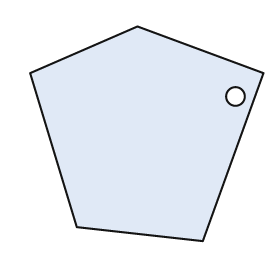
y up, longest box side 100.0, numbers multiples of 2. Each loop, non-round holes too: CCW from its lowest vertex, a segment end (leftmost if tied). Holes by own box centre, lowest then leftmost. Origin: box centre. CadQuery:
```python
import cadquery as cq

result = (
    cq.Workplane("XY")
    .moveTo(24.0, -46.0)
    .lineTo(50.0, 26.0)
    .lineTo(-4.0, 46.0)
    .lineTo(-50.0, 26.0)
    .lineTo(-30.0, -40.0)
    .close()
    .moveTo(38.0, 16.0)
    .circle(4.0)
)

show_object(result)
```